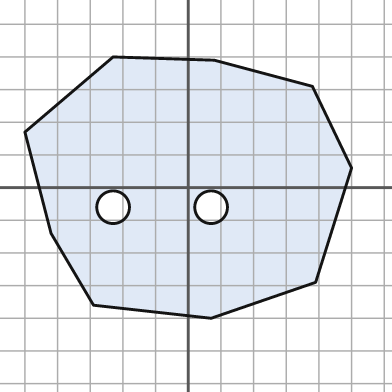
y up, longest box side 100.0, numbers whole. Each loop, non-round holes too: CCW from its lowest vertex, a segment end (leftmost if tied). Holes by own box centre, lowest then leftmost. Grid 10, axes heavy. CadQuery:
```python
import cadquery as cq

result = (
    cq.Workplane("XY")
    .moveTo(7.0, -40.0)
    .lineTo(39.0, -29.0)
    .lineTo(50.0, 6.0)
    .lineTo(38.0, 31.0)
    .lineTo(8.0, 39.0)
    .lineTo(-23.0, 40.0)
    .lineTo(-50.0, 17.0)
    .lineTo(-42.0, -14.0)
    .lineTo(-29.0, -36.0)
    .close()
    .moveTo(-23.0, -6.0)
    .circle(5.0)
    .moveTo(7.0, -6.0)
    .circle(5.0)
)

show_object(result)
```